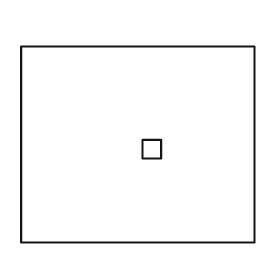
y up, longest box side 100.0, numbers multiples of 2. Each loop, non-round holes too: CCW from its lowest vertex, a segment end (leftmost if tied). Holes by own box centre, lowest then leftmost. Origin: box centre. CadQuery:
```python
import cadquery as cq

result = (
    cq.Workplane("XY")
    .moveTo(-50.0, -42.0)
    .lineTo(50.0, -42.0)
    .lineTo(50.0, 42.0)
    .lineTo(-50.0, 42.0)
    .close()
    .moveTo(2.0, -6.0)
    .lineTo(10.0, -6.0)
    .lineTo(10.0, 2.0)
    .lineTo(2.0, 2.0)
    .close()
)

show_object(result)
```